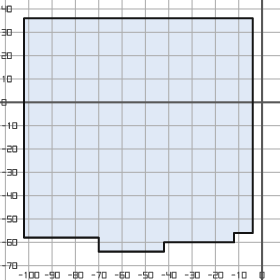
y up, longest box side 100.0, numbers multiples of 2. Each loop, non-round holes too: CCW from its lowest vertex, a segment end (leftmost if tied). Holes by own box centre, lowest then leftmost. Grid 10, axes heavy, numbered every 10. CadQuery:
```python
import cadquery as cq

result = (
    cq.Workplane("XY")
    .moveTo(-70.0, -64.0)
    .lineTo(-42.0, -64.0)
    .lineTo(-42.0, -60.0)
    .lineTo(-12.0, -60.0)
    .lineTo(-12.0, -56.0)
    .lineTo(-4.0, -56.0)
    .lineTo(-4.0, 36.0)
    .lineTo(-102.0, 36.0)
    .lineTo(-102.0, -58.0)
    .lineTo(-70.0, -58.0)
    .close()
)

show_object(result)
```